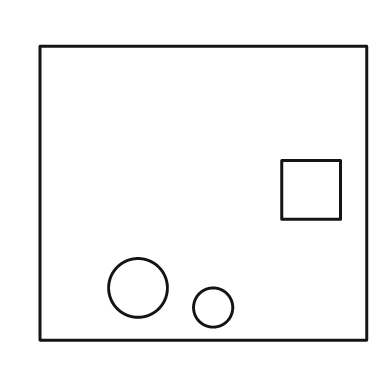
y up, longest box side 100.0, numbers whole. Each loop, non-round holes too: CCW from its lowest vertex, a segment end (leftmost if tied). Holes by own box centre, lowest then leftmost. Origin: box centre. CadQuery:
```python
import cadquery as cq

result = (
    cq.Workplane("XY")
    .moveTo(-50.0, -45.0)
    .lineTo(50.0, -45.0)
    .lineTo(50.0, 45.0)
    .lineTo(-50.0, 45.0)
    .close()
    .moveTo(3.0, -35.0)
    .circle(6.0)
    .moveTo(-20.0, -29.0)
    .circle(9.0)
    .moveTo(24.0, -8.0)
    .lineTo(42.0, -8.0)
    .lineTo(42.0, 10.0)
    .lineTo(24.0, 10.0)
    .close()
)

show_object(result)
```